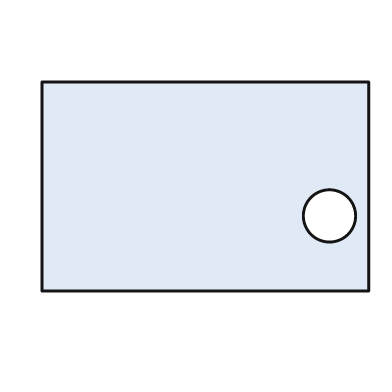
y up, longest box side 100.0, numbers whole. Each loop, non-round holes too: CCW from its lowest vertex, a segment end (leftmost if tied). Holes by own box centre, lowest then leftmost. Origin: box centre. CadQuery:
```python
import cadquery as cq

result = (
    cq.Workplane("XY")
    .moveTo(-50.0, -32.0)
    .lineTo(50.0, -32.0)
    .lineTo(50.0, 32.0)
    .lineTo(-50.0, 32.0)
    .close()
    .moveTo(38.0, -9.0)
    .circle(8.0)
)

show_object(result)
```